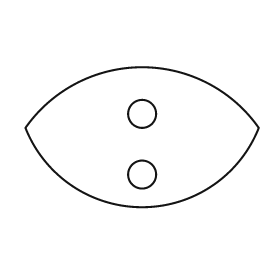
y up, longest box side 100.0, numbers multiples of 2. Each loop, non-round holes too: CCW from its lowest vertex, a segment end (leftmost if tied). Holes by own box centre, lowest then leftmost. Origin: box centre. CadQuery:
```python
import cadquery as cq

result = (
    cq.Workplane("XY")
    .moveTo(-50.0, 4.0)
    .threePointArc((0.0, -30.0), (50.0, 4.0))
    .threePointArc((0.0, 30.0), (-50.0, 4.0))
    .close()
    .moveTo(0.0, -16.0)
    .circle(6.0)
    .moveTo(0.0, 10.0)
    .circle(6.0)
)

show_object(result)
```